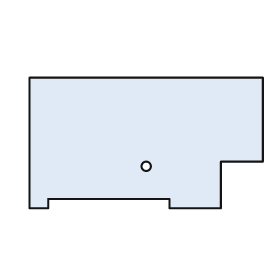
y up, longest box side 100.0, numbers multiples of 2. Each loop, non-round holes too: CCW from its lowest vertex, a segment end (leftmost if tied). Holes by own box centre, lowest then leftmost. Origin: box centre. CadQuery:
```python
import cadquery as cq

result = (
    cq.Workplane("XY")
    .moveTo(-50.0, -28.0)
    .lineTo(-42.0, -28.0)
    .lineTo(-42.0, -24.0)
    .lineTo(10.0, -24.0)
    .lineTo(10.0, -28.0)
    .lineTo(32.0, -28.0)
    .lineTo(32.0, -8.0)
    .lineTo(50.0, -8.0)
    .lineTo(50.0, 28.0)
    .lineTo(-50.0, 28.0)
    .close()
    .moveTo(0.0, -10.0)
    .circle(2.0)
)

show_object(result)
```